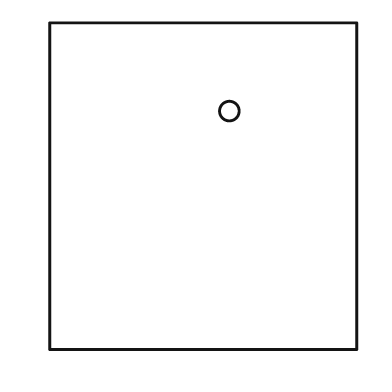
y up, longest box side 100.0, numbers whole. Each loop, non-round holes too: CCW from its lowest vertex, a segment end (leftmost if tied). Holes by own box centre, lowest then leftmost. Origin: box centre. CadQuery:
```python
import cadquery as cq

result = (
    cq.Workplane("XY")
    .moveTo(-47.0, -50.0)
    .lineTo(47.0, -50.0)
    .lineTo(47.0, 50.0)
    .lineTo(-47.0, 50.0)
    .close()
    .moveTo(8.0, 23.0)
    .circle(3.0)
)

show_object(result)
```